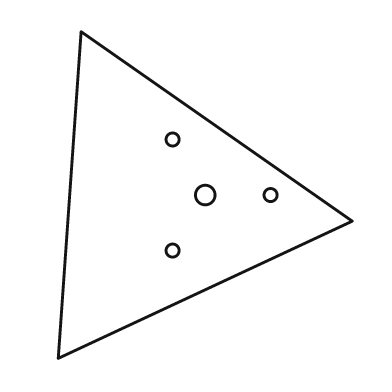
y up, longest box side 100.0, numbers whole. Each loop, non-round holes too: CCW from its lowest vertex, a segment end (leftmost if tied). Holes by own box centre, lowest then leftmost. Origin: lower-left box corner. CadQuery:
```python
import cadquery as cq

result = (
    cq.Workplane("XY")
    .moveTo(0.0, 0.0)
    .lineTo(90.0, 42.0)
    .lineTo(7.0, 100.0)
    .close()
    .moveTo(35.0, 33.0)
    .circle(2.0)
    .moveTo(45.0, 50.0)
    .circle(3.0)
    .moveTo(65.0, 50.0)
    .circle(2.0)
    .moveTo(35.0, 67.0)
    .circle(2.0)
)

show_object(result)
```